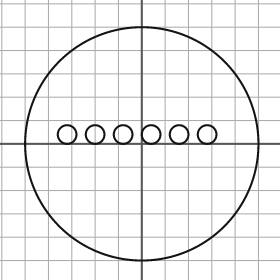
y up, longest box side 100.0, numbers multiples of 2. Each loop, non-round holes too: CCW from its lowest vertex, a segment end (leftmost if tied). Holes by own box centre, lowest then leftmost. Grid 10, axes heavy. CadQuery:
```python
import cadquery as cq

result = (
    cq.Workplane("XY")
    .moveTo(0.0, 0.0)
    .circle(50.0)
    .moveTo(-32.0, 4.0)
    .circle(4.0)
    .moveTo(-20.0, 4.0)
    .circle(4.0)
    .moveTo(-8.0, 4.0)
    .circle(4.0)
    .moveTo(4.0, 4.0)
    .circle(4.0)
    .moveTo(16.0, 4.0)
    .circle(4.0)
    .moveTo(28.0, 4.0)
    .circle(4.0)
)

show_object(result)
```